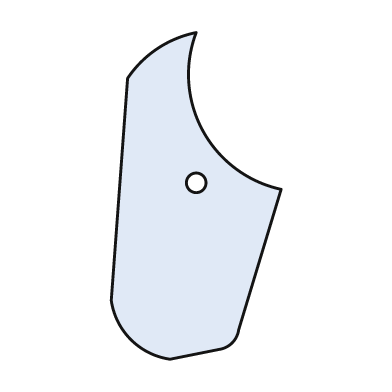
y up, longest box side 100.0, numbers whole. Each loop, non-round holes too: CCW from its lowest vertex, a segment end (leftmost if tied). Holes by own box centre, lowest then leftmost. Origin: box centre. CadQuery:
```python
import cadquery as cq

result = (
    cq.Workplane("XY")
    .moveTo(-8.0, -50.0)
    .lineTo(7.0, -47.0)
    .threePointArc((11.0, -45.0), (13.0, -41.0))
    .lineTo(26.0, 2.0)
    .threePointArc((2.0, 20.0), (0.0, 50.0))
    .threePointArc((-12.0, 45.0), (-21.0, 36.0))
    .lineTo(-26.0, -32.0)
    .threePointArc((-20.0, -44.0), (-8.0, -50.0))
    .close()
    .moveTo(0.0, 4.0)
    .circle(3.0)
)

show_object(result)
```